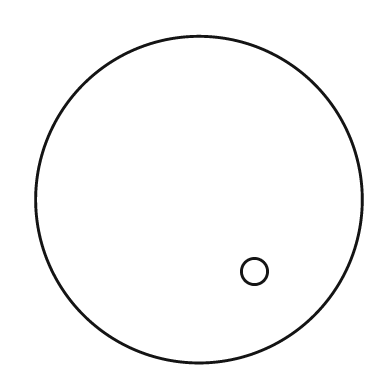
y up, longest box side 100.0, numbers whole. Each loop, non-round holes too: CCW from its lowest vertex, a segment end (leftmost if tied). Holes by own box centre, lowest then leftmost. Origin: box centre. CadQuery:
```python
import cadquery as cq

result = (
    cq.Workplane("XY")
    .moveTo(0.0, 0.0)
    .circle(50.0)
    .moveTo(17.0, -22.0)
    .circle(4.0)
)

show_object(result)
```